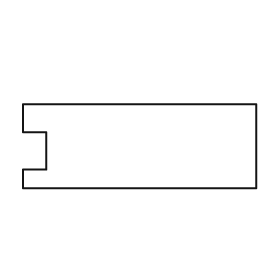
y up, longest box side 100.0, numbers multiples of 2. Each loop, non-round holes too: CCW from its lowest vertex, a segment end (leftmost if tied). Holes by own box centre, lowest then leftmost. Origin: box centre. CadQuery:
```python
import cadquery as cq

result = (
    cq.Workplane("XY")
    .moveTo(-50.0, -18.0)
    .lineTo(50.0, -18.0)
    .lineTo(50.0, 18.0)
    .lineTo(-50.0, 18.0)
    .lineTo(-50.0, 6.0)
    .lineTo(-40.0, 6.0)
    .lineTo(-40.0, -10.0)
    .lineTo(-50.0, -10.0)
    .close()
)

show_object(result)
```